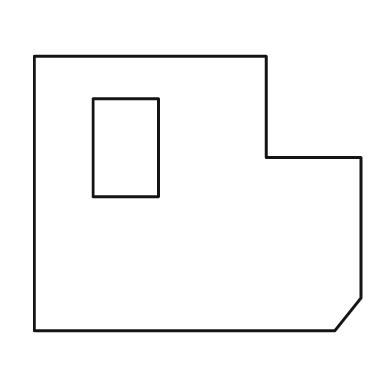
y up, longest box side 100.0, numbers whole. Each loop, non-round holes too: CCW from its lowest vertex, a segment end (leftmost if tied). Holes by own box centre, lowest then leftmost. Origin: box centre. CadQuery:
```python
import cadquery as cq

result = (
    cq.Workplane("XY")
    .moveTo(-50.0, -42.0)
    .lineTo(42.0, -42.0)
    .lineTo(50.0, -32.0)
    .lineTo(50.0, 11.0)
    .lineTo(21.0, 11.0)
    .lineTo(21.0, 42.0)
    .lineTo(-50.0, 42.0)
    .close()
    .moveTo(-32.0, -1.0)
    .lineTo(-12.0, -1.0)
    .lineTo(-12.0, 29.0)
    .lineTo(-32.0, 29.0)
    .close()
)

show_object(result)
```